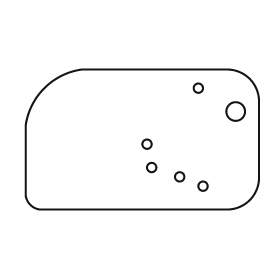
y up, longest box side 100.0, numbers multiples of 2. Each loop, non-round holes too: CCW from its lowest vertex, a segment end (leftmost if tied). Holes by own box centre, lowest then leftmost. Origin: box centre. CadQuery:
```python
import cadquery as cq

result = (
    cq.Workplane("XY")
    .moveTo(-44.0, -30.0)
    .lineTo(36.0, -30.0)
    .threePointArc((46.0, -26.0), (50.0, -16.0))
    .lineTo(50.0, 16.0)
    .threePointArc((46.0, 26.0), (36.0, 30.0))
    .lineTo(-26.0, 30.0)
    .threePointArc((-42.0, 22.0), (-50.0, 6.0))
    .lineTo(-50.0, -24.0)
    .threePointArc((-48.0, -28.0), (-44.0, -30.0))
    .close()
    .moveTo(26.0, -20.0)
    .circle(2.0)
    .moveTo(16.0, -16.0)
    .circle(2.0)
    .moveTo(4.0, -12.0)
    .circle(2.0)
    .moveTo(2.0, -2.0)
    .circle(2.0)
    .moveTo(40.0, 12.0)
    .circle(4.0)
    .moveTo(24.0, 22.0)
    .circle(2.0)
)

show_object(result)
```